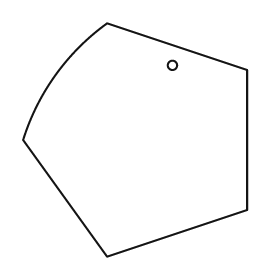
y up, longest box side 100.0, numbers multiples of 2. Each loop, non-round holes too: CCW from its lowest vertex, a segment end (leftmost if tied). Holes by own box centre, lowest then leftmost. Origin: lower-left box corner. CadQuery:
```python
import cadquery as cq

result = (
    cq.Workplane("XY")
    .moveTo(36.0, 0.0)
    .lineTo(96.0, 20.0)
    .lineTo(96.0, 80.0)
    .lineTo(36.0, 100.0)
    .threePointArc((14.0, 78.0), (0.0, 50.0))
    .close()
    .moveTo(64.0, 82.0)
    .circle(2.0)
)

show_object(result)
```